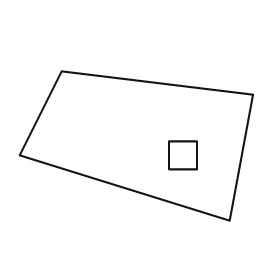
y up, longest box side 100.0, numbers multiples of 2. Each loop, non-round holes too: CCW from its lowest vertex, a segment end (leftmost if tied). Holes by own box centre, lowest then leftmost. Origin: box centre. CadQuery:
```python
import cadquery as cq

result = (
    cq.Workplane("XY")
    .moveTo(40.0, -32.0)
    .lineTo(50.0, 22.0)
    .lineTo(-32.0, 32.0)
    .lineTo(-50.0, -4.0)
    .close()
    .moveTo(14.0, -10.0)
    .lineTo(26.0, -10.0)
    .lineTo(26.0, 2.0)
    .lineTo(14.0, 2.0)
    .close()
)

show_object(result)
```